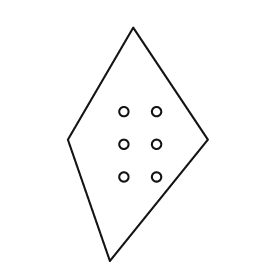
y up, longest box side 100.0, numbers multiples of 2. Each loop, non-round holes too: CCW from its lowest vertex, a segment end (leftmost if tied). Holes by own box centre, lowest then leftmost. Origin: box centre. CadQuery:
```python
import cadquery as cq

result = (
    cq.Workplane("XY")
    .moveTo(-12.0, -50.0)
    .lineTo(30.0, 2.0)
    .lineTo(-2.0, 50.0)
    .lineTo(-30.0, 2.0)
    .close()
    .moveTo(-6.0, -14.0)
    .circle(2.0)
    .moveTo(8.0, -14.0)
    .circle(2.0)
    .moveTo(-6.0, 0.0)
    .circle(2.0)
    .moveTo(8.0, 0.0)
    .circle(2.0)
    .moveTo(-6.0, 14.0)
    .circle(2.0)
    .moveTo(8.0, 14.0)
    .circle(2.0)
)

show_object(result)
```